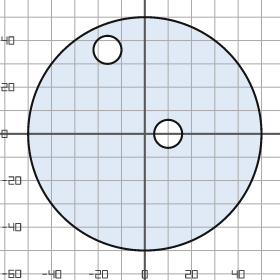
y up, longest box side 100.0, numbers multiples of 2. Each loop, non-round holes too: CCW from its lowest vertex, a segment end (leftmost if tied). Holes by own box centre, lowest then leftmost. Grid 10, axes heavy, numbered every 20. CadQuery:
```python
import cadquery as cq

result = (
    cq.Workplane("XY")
    .moveTo(0.0, 0.0)
    .circle(50.0)
    .moveTo(10.0, 0.0)
    .circle(6.0)
    .moveTo(-16.0, 36.0)
    .circle(6.0)
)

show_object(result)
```